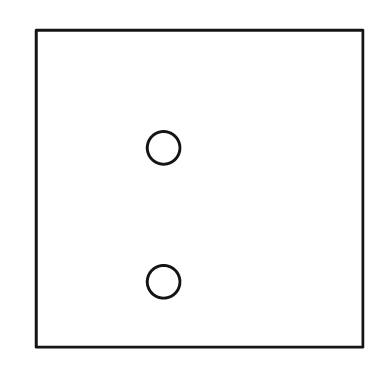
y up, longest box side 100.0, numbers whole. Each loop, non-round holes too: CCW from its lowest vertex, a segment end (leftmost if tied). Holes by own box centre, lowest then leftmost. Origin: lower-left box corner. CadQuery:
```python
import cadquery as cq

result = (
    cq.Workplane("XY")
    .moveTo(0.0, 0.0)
    .lineTo(100.0, 0.0)
    .lineTo(100.0, 97.0)
    .lineTo(0.0, 97.0)
    .close()
    .moveTo(39.0, 20.0)
    .circle(5.0)
    .moveTo(39.0, 61.0)
    .circle(5.0)
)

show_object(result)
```